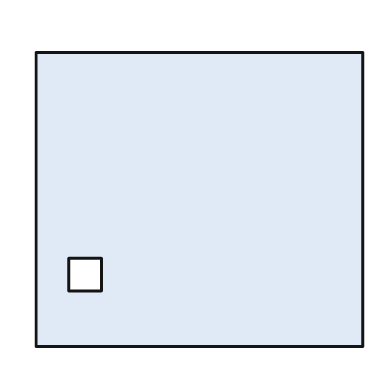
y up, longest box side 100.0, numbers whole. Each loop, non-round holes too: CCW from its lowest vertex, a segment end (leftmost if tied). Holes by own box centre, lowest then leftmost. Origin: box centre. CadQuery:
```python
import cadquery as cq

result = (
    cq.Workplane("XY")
    .moveTo(-50.0, -45.0)
    .lineTo(50.0, -45.0)
    .lineTo(50.0, 45.0)
    .lineTo(-50.0, 45.0)
    .close()
    .moveTo(-40.0, -28.0)
    .lineTo(-30.0, -28.0)
    .lineTo(-30.0, -18.0)
    .lineTo(-40.0, -18.0)
    .close()
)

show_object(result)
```